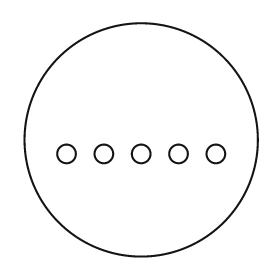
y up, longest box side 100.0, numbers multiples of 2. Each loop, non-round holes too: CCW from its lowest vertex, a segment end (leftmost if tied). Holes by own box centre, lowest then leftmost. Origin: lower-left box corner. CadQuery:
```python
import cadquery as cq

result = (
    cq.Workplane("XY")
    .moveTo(50.0, 50.0)
    .circle(50.0)
    .moveTo(18.0, 44.0)
    .circle(4.0)
    .moveTo(34.0, 44.0)
    .circle(4.0)
    .moveTo(50.0, 44.0)
    .circle(4.0)
    .moveTo(66.0, 44.0)
    .circle(4.0)
    .moveTo(82.0, 44.0)
    .circle(4.0)
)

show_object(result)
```